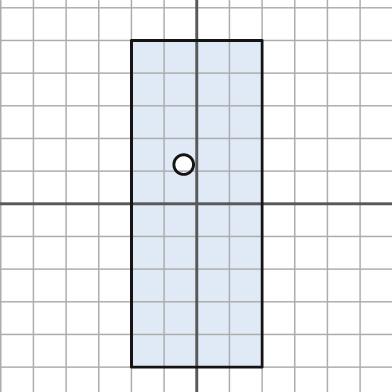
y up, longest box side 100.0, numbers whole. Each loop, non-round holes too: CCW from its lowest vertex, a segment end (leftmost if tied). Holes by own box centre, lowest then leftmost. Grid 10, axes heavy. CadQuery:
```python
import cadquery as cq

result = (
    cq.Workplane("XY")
    .moveTo(-20.0, -50.0)
    .lineTo(20.0, -50.0)
    .lineTo(20.0, 50.0)
    .lineTo(-20.0, 50.0)
    .close()
    .moveTo(-4.0, 12.0)
    .circle(3.0)
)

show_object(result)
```